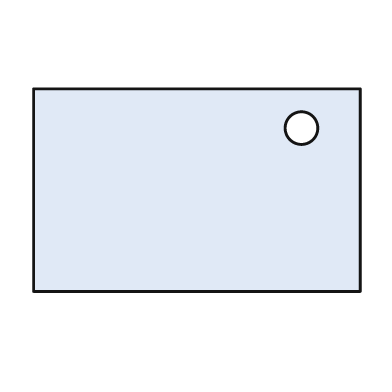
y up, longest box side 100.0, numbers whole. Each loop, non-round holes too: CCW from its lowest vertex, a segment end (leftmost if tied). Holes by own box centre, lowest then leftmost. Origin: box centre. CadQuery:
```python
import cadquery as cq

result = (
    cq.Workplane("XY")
    .moveTo(-50.0, -31.0)
    .lineTo(50.0, -31.0)
    .lineTo(50.0, 31.0)
    .lineTo(-50.0, 31.0)
    .close()
    .moveTo(32.0, 19.0)
    .circle(5.0)
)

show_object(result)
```